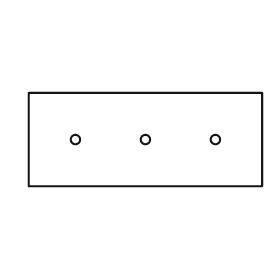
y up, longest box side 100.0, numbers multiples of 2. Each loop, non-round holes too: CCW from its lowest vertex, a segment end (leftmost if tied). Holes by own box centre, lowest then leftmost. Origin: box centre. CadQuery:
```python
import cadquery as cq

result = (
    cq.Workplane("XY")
    .moveTo(-50.0, -20.0)
    .lineTo(50.0, -20.0)
    .lineTo(50.0, 20.0)
    .lineTo(-50.0, 20.0)
    .close()
    .moveTo(-30.0, 0.0)
    .circle(2.0)
    .moveTo(0.0, 0.0)
    .circle(2.0)
    .moveTo(30.0, 0.0)
    .circle(2.0)
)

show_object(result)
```